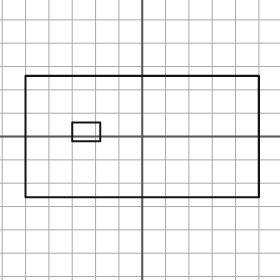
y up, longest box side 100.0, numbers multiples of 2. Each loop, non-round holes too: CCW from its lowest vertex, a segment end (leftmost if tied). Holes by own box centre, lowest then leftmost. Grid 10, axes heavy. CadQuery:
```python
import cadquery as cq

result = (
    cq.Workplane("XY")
    .moveTo(-50.0, -26.0)
    .lineTo(50.0, -26.0)
    .lineTo(50.0, 26.0)
    .lineTo(-50.0, 26.0)
    .close()
    .moveTo(-30.0, -2.0)
    .lineTo(-18.0, -2.0)
    .lineTo(-18.0, 6.0)
    .lineTo(-30.0, 6.0)
    .close()
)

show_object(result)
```